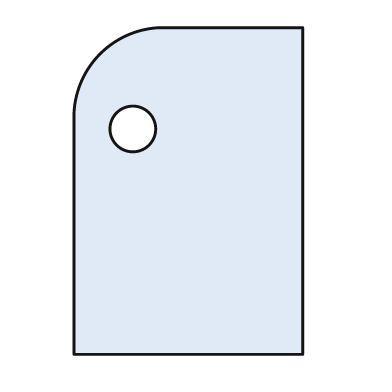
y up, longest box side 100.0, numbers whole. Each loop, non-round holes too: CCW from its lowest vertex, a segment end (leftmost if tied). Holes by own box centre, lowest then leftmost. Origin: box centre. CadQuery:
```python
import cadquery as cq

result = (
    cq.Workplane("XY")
    .moveTo(-35.0, -50.0)
    .lineTo(35.0, -50.0)
    .lineTo(35.0, 50.0)
    .lineTo(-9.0, 50.0)
    .threePointArc((-27.0, 42.0), (-35.0, 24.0))
    .close()
    .moveTo(-17.0, 19.0)
    .circle(7.0)
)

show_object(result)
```